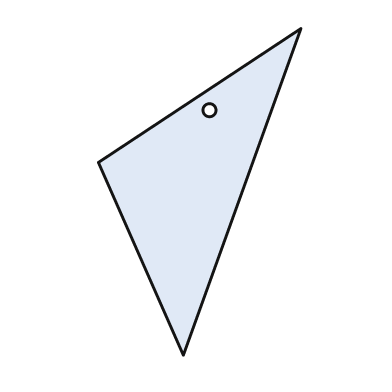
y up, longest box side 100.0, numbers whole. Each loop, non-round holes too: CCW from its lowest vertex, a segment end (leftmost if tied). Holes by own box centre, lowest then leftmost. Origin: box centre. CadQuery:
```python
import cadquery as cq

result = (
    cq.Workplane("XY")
    .moveTo(-5.0, -50.0)
    .lineTo(31.0, 50.0)
    .lineTo(-31.0, 9.0)
    .close()
    .moveTo(3.0, 25.0)
    .circle(2.0)
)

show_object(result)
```